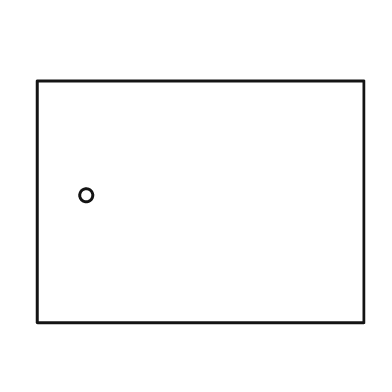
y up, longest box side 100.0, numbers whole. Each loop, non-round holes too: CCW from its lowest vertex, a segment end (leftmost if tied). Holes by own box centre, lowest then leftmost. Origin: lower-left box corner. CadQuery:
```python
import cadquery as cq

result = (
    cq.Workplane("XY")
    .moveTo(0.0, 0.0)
    .lineTo(100.0, 0.0)
    .lineTo(100.0, 74.0)
    .lineTo(0.0, 74.0)
    .close()
    .moveTo(15.0, 39.0)
    .circle(2.0)
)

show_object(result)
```